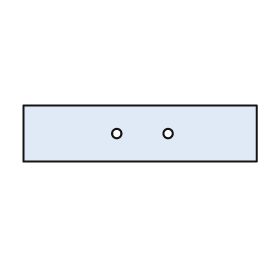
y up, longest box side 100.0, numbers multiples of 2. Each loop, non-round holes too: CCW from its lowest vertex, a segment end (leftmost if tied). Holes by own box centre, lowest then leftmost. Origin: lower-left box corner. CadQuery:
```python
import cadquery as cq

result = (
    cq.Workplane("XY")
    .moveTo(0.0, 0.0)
    .lineTo(100.0, 0.0)
    .lineTo(100.0, 24.0)
    .lineTo(0.0, 24.0)
    .close()
    .moveTo(40.0, 12.0)
    .circle(2.0)
    .moveTo(62.0, 12.0)
    .circle(2.0)
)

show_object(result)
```